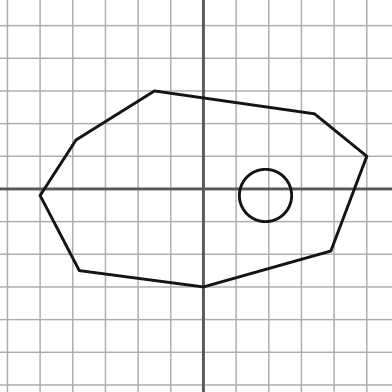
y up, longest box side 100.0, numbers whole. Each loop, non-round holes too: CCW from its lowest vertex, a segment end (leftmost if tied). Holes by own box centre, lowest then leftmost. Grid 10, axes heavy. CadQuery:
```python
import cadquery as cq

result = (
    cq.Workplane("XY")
    .moveTo(0.0, -30.0)
    .lineTo(39.0, -19.0)
    .lineTo(50.0, 10.0)
    .lineTo(34.0, 23.0)
    .lineTo(-15.0, 30.0)
    .lineTo(-39.0, 15.0)
    .lineTo(-50.0, -2.0)
    .lineTo(-38.0, -25.0)
    .close()
    .moveTo(19.0, -2.0)
    .circle(8.0)
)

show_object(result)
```